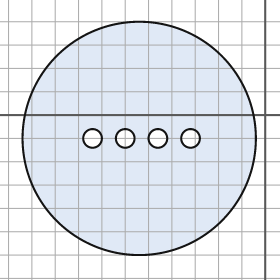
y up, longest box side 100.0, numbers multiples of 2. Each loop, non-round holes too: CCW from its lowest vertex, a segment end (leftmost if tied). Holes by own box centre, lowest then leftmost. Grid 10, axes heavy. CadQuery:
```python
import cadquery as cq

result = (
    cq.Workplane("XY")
    .moveTo(-54.0, -10.0)
    .circle(50.0)
    .moveTo(-74.0, -10.0)
    .circle(4.0)
    .moveTo(-60.0, -10.0)
    .circle(4.0)
    .moveTo(-46.0, -10.0)
    .circle(4.0)
    .moveTo(-32.0, -10.0)
    .circle(4.0)
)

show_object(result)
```